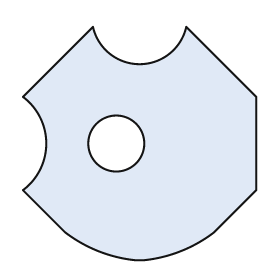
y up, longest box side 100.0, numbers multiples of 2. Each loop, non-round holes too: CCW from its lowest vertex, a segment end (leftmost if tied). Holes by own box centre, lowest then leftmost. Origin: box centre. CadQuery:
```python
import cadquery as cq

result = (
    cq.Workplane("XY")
    .moveTo(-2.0, -50.0)
    .lineTo(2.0, -50.0)
    .threePointArc((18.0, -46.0), (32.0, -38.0))
    .lineTo(50.0, -20.0)
    .lineTo(50.0, 20.0)
    .lineTo(20.0, 50.0)
    .threePointArc((0.0, 34.0), (-20.0, 50.0))
    .lineTo(-50.0, 20.0)
    .threePointArc((-40.0, 0.0), (-50.0, -20.0))
    .lineTo(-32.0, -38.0)
    .threePointArc((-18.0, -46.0), (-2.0, -50.0))
    .close()
    .moveTo(-10.0, 0.0)
    .circle(12.0)
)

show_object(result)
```